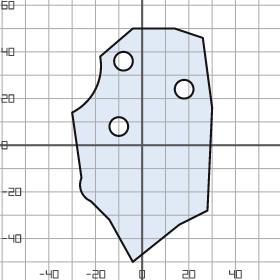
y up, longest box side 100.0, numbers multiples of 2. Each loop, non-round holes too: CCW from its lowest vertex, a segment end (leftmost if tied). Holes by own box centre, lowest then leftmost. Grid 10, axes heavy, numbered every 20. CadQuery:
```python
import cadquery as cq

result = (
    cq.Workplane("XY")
    .moveTo(-4.0, -50.0)
    .lineTo(16.0, -34.0)
    .lineTo(28.0, -28.0)
    .lineTo(30.0, 16.0)
    .lineTo(26.0, 46.0)
    .lineTo(14.0, 50.0)
    .lineTo(-4.0, 50.0)
    .lineTo(-18.0, 38.0)
    .threePointArc((-20.0, 24.0), (-30.0, 14.0))
    .lineTo(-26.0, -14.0)
    .threePointArc((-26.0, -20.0), (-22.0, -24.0))
    .lineTo(-14.0, -32.0)
    .close()
    .moveTo(-10.0, 8.0)
    .circle(4.0)
    .moveTo(18.0, 24.0)
    .circle(4.0)
    .moveTo(-8.0, 36.0)
    .circle(4.0)
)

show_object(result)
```